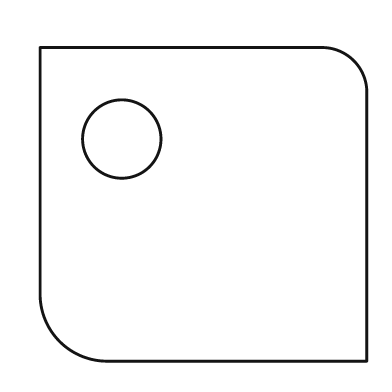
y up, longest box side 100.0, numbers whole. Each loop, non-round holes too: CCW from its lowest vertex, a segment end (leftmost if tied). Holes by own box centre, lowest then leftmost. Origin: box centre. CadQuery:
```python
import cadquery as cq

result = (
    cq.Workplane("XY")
    .moveTo(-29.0, -48.0)
    .lineTo(50.0, -48.0)
    .lineTo(50.0, 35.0)
    .threePointArc((46.0, 44.0), (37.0, 48.0))
    .lineTo(-50.0, 48.0)
    .lineTo(-50.0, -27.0)
    .threePointArc((-44.0, -42.0), (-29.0, -48.0))
    .close()
    .moveTo(-25.0, 20.0)
    .circle(12.0)
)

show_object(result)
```